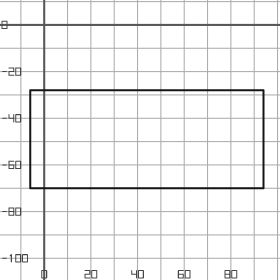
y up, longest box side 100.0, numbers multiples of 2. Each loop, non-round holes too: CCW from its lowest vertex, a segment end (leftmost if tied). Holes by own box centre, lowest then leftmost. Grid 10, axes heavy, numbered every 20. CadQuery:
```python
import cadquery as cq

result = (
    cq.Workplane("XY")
    .moveTo(-6.0, -70.0)
    .lineTo(94.0, -70.0)
    .lineTo(94.0, -28.0)
    .lineTo(-6.0, -28.0)
    .close()
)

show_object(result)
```